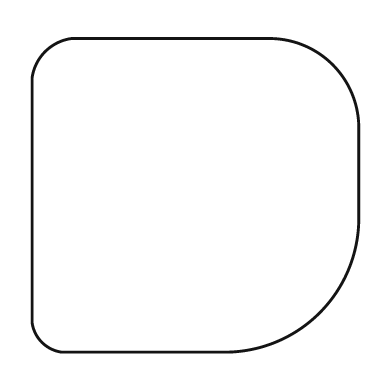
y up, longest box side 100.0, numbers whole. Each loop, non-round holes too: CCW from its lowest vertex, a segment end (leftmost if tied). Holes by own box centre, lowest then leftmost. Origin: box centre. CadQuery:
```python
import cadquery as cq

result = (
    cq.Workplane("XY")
    .moveTo(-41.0, -48.0)
    .lineTo(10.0, -48.0)
    .threePointArc((38.0, -36.0), (50.0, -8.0))
    .lineTo(50.0, 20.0)
    .threePointArc((42.0, 40.0), (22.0, 48.0))
    .lineTo(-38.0, 48.0)
    .threePointArc((-46.0, 44.0), (-50.0, 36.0))
    .lineTo(-50.0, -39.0)
    .threePointArc((-47.0, -45.0), (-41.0, -48.0))
    .close()
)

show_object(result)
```